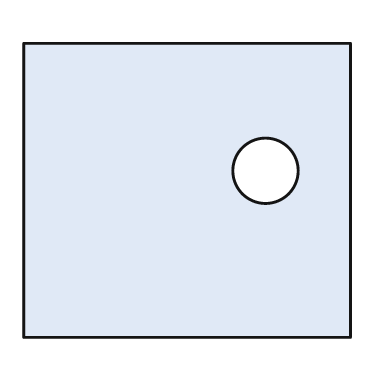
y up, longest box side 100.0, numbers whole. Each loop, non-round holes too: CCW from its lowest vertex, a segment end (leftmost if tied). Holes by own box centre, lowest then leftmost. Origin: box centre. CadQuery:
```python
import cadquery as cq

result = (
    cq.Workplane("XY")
    .moveTo(-50.0, -45.0)
    .lineTo(50.0, -45.0)
    .lineTo(50.0, 45.0)
    .lineTo(-50.0, 45.0)
    .close()
    .moveTo(24.0, 6.0)
    .circle(10.0)
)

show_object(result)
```